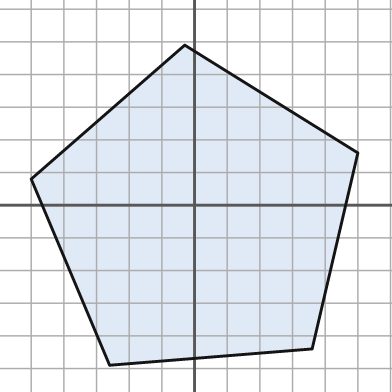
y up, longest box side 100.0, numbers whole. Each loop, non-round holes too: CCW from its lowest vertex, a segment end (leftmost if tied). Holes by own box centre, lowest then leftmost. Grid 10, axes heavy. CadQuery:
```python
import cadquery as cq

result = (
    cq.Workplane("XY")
    .moveTo(-26.0, -49.0)
    .lineTo(36.0, -44.0)
    .lineTo(50.0, 16.0)
    .lineTo(-3.0, 49.0)
    .lineTo(-50.0, 8.0)
    .close()
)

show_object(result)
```